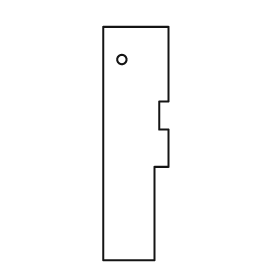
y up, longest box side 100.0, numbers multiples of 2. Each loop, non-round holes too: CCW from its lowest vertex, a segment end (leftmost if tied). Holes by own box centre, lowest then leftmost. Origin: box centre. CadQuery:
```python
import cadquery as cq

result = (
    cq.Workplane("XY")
    .moveTo(-14.0, -50.0)
    .lineTo(8.0, -50.0)
    .lineTo(8.0, -10.0)
    .lineTo(14.0, -10.0)
    .lineTo(14.0, 6.0)
    .lineTo(10.0, 6.0)
    .lineTo(10.0, 18.0)
    .lineTo(14.0, 18.0)
    .lineTo(14.0, 50.0)
    .lineTo(-14.0, 50.0)
    .close()
    .moveTo(-6.0, 36.0)
    .circle(2.0)
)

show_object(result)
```